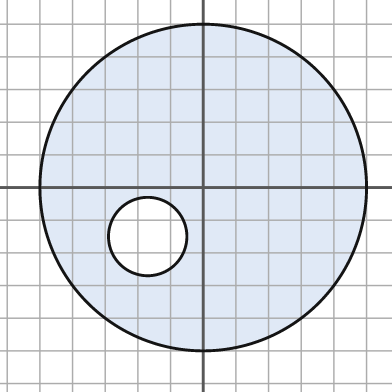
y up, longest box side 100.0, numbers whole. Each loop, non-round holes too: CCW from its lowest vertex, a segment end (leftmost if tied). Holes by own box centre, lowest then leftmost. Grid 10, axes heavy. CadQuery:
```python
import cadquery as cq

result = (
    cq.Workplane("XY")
    .moveTo(0.0, 0.0)
    .circle(50.0)
    .moveTo(-17.0, -15.0)
    .circle(12.0)
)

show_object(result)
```